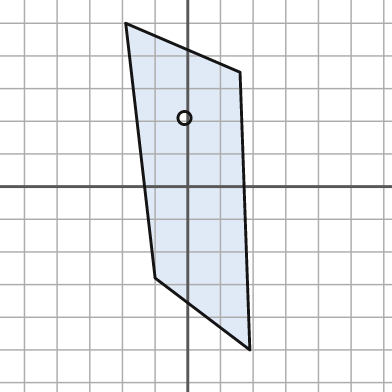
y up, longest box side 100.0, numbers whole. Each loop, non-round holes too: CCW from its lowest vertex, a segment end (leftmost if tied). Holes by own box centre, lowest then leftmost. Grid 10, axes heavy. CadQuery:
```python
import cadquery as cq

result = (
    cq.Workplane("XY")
    .moveTo(19.0, -50.0)
    .lineTo(16.0, 35.0)
    .lineTo(-19.0, 50.0)
    .lineTo(-10.0, -28.0)
    .close()
    .moveTo(-1.0, 21.0)
    .circle(2.0)
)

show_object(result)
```